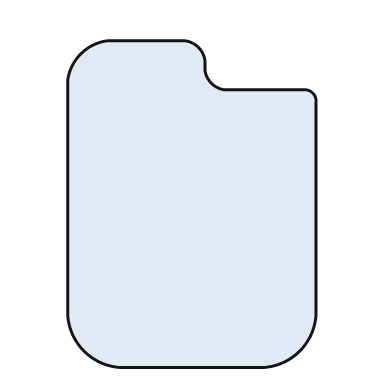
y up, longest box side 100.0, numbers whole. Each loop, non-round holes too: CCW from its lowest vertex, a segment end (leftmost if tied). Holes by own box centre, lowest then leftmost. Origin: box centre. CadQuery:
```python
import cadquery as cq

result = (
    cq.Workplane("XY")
    .moveTo(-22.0, -50.0)
    .lineTo(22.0, -50.0)
    .threePointArc((33.0, -45.0), (38.0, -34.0))
    .lineTo(38.0, 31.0)
    .threePointArc((37.0, 34.0), (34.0, 35.0))
    .lineTo(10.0, 35.0)
    .threePointArc((6.0, 37.0), (4.0, 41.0))
    .lineTo(4.0, 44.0)
    .threePointArc((2.0, 48.0), (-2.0, 50.0))
    .lineTo(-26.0, 50.0)
    .threePointArc((-34.0, 46.0), (-38.0, 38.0))
    .lineTo(-38.0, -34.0)
    .threePointArc((-33.0, -45.0), (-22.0, -50.0))
    .close()
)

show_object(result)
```